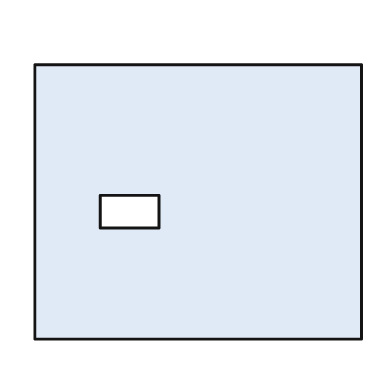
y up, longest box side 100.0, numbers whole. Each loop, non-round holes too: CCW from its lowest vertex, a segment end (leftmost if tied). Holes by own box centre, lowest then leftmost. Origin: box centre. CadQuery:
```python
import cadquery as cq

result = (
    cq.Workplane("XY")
    .moveTo(-50.0, -42.0)
    .lineTo(50.0, -42.0)
    .lineTo(50.0, 42.0)
    .lineTo(-50.0, 42.0)
    .close()
    .moveTo(-30.0, -8.0)
    .lineTo(-12.0, -8.0)
    .lineTo(-12.0, 2.0)
    .lineTo(-30.0, 2.0)
    .close()
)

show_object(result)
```